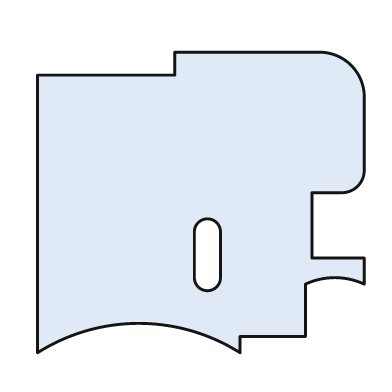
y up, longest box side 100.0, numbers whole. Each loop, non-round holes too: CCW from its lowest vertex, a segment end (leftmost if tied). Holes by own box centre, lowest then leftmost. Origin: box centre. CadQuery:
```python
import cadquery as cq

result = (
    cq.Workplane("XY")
    .moveTo(-50.0, -46.0)
    .threePointArc((-19.0, -37.0), (12.0, -46.0))
    .lineTo(12.0, -41.0)
    .lineTo(32.0, -41.0)
    .lineTo(32.0, -25.0)
    .threePointArc((41.0, -23.0), (50.0, -25.0))
    .lineTo(50.0, -17.0)
    .lineTo(34.0, -17.0)
    .lineTo(34.0, 3.0)
    .lineTo(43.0, 3.0)
    .threePointArc((48.0, 5.0), (50.0, 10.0))
    .lineTo(50.0, 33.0)
    .threePointArc((46.0, 42.0), (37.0, 46.0))
    .lineTo(-8.0, 46.0)
    .lineTo(-8.0, 39.0)
    .lineTo(-50.0, 39.0)
    .close()
    .moveTo(-2.0, -23.0)
    .threePointArc((2.0, -27.0), (6.0, -23.0))
    .lineTo(6.0, -9.0)
    .threePointArc((2.0, -5.0), (-2.0, -9.0))
    .close()
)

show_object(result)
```